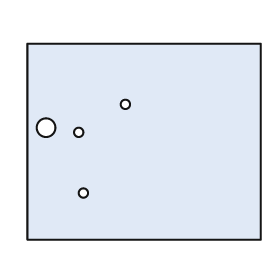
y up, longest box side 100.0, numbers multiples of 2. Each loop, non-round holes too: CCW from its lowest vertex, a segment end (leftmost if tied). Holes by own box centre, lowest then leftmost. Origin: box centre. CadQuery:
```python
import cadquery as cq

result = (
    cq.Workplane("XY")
    .moveTo(-50.0, -42.0)
    .lineTo(50.0, -42.0)
    .lineTo(50.0, 42.0)
    .lineTo(-50.0, 42.0)
    .close()
    .moveTo(-26.0, -22.0)
    .circle(2.0)
    .moveTo(-28.0, 4.0)
    .circle(2.0)
    .moveTo(-42.0, 6.0)
    .circle(4.0)
    .moveTo(-8.0, 16.0)
    .circle(2.0)
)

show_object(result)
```